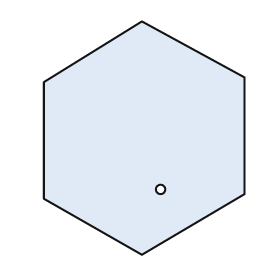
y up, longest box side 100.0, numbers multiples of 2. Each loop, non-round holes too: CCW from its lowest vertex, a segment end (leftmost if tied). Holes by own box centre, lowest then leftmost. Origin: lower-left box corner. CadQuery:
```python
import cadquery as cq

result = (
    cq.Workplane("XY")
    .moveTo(42.0, 0.0)
    .lineTo(86.0, 26.0)
    .lineTo(86.0, 76.0)
    .lineTo(42.0, 100.0)
    .lineTo(0.0, 74.0)
    .lineTo(0.0, 24.0)
    .close()
    .moveTo(50.0, 28.0)
    .circle(2.0)
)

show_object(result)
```